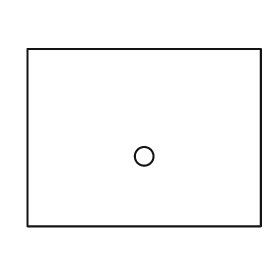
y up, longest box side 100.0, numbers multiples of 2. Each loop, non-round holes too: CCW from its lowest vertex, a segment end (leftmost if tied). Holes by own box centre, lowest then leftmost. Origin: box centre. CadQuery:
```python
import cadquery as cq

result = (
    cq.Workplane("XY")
    .moveTo(-50.0, -38.0)
    .lineTo(50.0, -38.0)
    .lineTo(50.0, 38.0)
    .lineTo(-50.0, 38.0)
    .close()
    .moveTo(0.0, -8.0)
    .circle(4.0)
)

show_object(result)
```